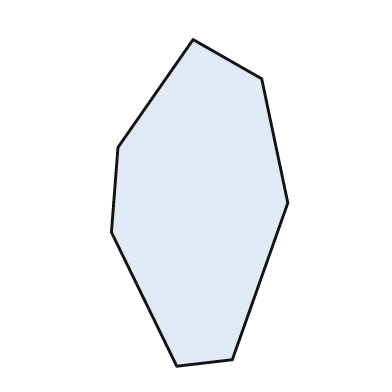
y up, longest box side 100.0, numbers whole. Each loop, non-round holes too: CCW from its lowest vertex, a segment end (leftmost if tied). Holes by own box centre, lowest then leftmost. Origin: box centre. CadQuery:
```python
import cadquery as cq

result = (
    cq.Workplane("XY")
    .moveTo(-7.0, -50.0)
    .lineTo(10.0, -48.0)
    .lineTo(27.0, 0.0)
    .lineTo(19.0, 38.0)
    .lineTo(-2.0, 50.0)
    .lineTo(-25.0, 17.0)
    .lineTo(-27.0, -9.0)
    .close()
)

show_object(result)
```